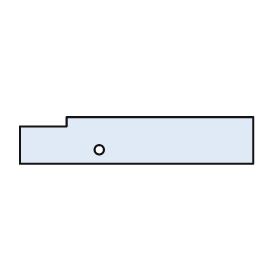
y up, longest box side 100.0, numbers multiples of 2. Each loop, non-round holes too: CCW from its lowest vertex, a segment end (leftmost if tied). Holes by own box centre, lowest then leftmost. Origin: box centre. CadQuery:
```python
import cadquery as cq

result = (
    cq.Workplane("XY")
    .moveTo(-50.0, -10.0)
    .lineTo(50.0, -10.0)
    .lineTo(50.0, 10.0)
    .lineTo(-30.0, 10.0)
    .lineTo(-30.0, 6.0)
    .lineTo(-50.0, 6.0)
    .close()
    .moveTo(-16.0, -4.0)
    .circle(2.0)
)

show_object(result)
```